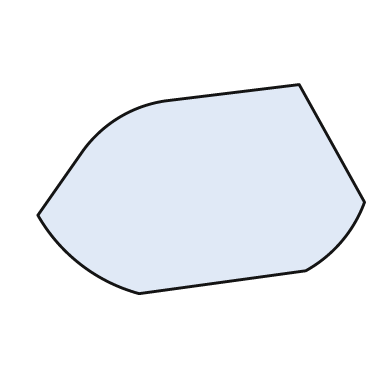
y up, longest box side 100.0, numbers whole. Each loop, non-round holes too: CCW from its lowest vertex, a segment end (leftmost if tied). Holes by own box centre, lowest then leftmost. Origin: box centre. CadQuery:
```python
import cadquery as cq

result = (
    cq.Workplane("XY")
    .moveTo(-19.0, -32.0)
    .lineTo(32.0, -25.0)
    .threePointArc((43.0, -16.0), (50.0, -4.0))
    .lineTo(30.0, 32.0)
    .lineTo(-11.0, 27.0)
    .threePointArc((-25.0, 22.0), (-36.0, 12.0))
    .lineTo(-50.0, -8.0)
    .threePointArc((-37.0, -23.0), (-19.0, -32.0))
    .close()
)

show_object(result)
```